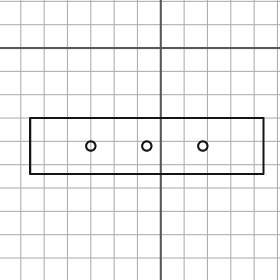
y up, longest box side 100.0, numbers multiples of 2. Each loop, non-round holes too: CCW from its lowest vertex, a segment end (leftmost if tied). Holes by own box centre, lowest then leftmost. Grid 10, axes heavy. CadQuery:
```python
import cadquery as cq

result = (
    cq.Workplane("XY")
    .moveTo(-56.0, -54.0)
    .lineTo(44.0, -54.0)
    .lineTo(44.0, -30.0)
    .lineTo(-56.0, -30.0)
    .close()
    .moveTo(-30.0, -42.0)
    .circle(2.0)
    .moveTo(-6.0, -42.0)
    .circle(2.0)
    .moveTo(18.0, -42.0)
    .circle(2.0)
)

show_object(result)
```